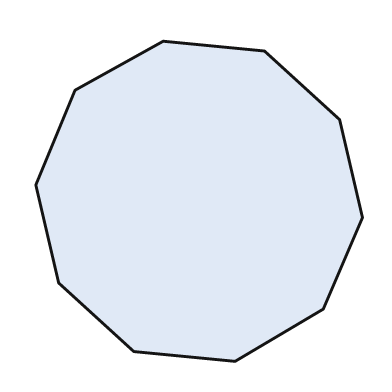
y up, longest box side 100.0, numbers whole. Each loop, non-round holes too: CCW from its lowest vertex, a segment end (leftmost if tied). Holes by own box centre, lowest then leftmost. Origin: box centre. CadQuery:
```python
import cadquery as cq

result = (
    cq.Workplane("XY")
    .moveTo(11.0, -49.0)
    .lineTo(38.0, -33.0)
    .lineTo(50.0, -5.0)
    .lineTo(43.0, 25.0)
    .lineTo(20.0, 46.0)
    .lineTo(-11.0, 49.0)
    .lineTo(-38.0, 34.0)
    .lineTo(-50.0, 5.0)
    .lineTo(-43.0, -25.0)
    .lineTo(-20.0, -46.0)
    .close()
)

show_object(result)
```